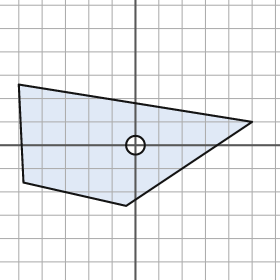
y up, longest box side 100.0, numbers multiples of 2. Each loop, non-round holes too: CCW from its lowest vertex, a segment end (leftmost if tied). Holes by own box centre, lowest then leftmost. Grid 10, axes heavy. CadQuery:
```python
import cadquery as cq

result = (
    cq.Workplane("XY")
    .moveTo(-4.0, -26.0)
    .lineTo(50.0, 10.0)
    .lineTo(-50.0, 26.0)
    .lineTo(-48.0, -16.0)
    .close()
    .moveTo(0.0, 0.0)
    .circle(4.0)
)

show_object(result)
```